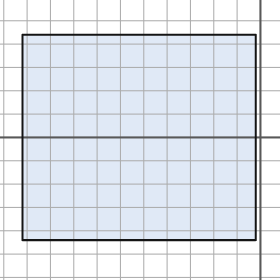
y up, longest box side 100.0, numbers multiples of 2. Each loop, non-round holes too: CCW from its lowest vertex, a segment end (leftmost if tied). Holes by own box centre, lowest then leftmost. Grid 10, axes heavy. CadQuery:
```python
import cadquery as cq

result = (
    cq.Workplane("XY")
    .moveTo(-102.0, -44.0)
    .lineTo(-2.0, -44.0)
    .lineTo(-2.0, 44.0)
    .lineTo(-102.0, 44.0)
    .close()
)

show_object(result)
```